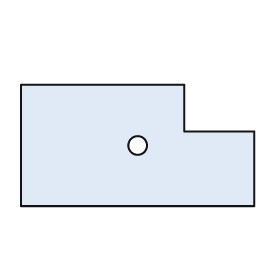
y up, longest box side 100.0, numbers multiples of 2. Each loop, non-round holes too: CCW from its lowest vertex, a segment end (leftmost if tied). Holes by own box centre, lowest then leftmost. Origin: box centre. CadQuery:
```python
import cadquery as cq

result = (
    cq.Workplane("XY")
    .moveTo(-50.0, -26.0)
    .lineTo(50.0, -26.0)
    .lineTo(50.0, 6.0)
    .lineTo(20.0, 6.0)
    .lineTo(20.0, 26.0)
    .lineTo(-50.0, 26.0)
    .close()
    .moveTo(0.0, 0.0)
    .circle(4.0)
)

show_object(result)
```